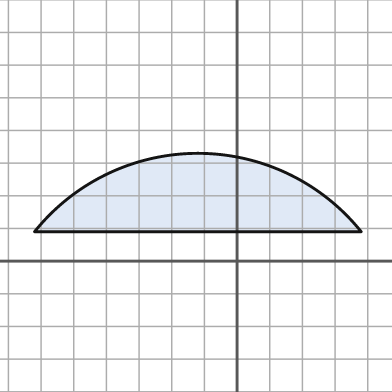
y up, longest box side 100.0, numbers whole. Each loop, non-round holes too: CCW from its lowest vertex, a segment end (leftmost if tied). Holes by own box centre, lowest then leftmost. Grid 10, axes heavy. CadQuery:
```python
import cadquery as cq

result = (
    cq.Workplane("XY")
    .moveTo(-62.0, 9.0)
    .lineTo(38.0, 9.0)
    .threePointArc((-12.0, 33.0), (-62.0, 9.0))
    .close()
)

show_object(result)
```